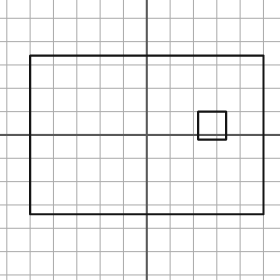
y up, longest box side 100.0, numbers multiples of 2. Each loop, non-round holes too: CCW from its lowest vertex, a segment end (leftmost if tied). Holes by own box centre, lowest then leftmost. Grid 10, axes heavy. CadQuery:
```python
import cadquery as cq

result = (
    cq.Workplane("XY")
    .moveTo(-50.0, -34.0)
    .lineTo(50.0, -34.0)
    .lineTo(50.0, 34.0)
    .lineTo(-50.0, 34.0)
    .close()
    .moveTo(22.0, -2.0)
    .lineTo(34.0, -2.0)
    .lineTo(34.0, 10.0)
    .lineTo(22.0, 10.0)
    .close()
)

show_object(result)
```